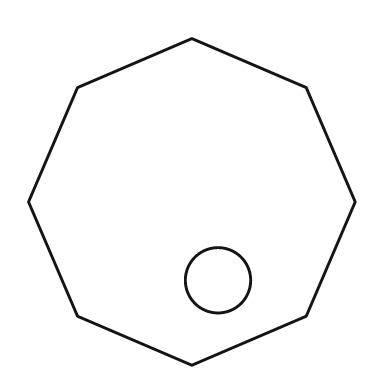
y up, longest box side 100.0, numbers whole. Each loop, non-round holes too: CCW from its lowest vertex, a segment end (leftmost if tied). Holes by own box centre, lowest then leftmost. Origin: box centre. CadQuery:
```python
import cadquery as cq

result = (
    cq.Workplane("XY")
    .moveTo(0.0, -50.0)
    .lineTo(35.0, -35.0)
    .lineTo(50.0, 0.0)
    .lineTo(35.0, 35.0)
    .lineTo(0.0, 50.0)
    .lineTo(-35.0, 35.0)
    .lineTo(-50.0, 0.0)
    .lineTo(-35.0, -35.0)
    .close()
    .moveTo(8.0, -24.0)
    .circle(10.0)
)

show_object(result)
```